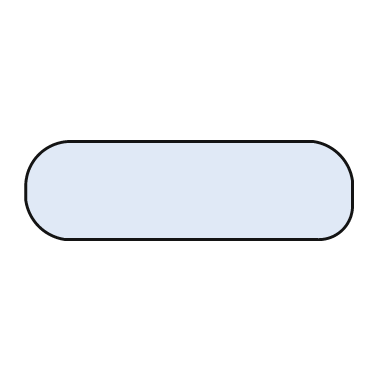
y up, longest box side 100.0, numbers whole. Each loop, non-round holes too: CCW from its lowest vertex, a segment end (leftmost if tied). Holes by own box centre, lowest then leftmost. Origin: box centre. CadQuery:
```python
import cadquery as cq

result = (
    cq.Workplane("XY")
    .moveTo(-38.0, -15.0)
    .lineTo(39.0, -15.0)
    .threePointArc((47.0, -12.0), (50.0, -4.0))
    .lineTo(50.0, 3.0)
    .threePointArc((46.0, 11.0), (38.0, 15.0))
    .lineTo(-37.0, 15.0)
    .threePointArc((-46.0, 11.0), (-50.0, 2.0))
    .lineTo(-50.0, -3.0)
    .threePointArc((-46.0, -11.0), (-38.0, -15.0))
    .close()
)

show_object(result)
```